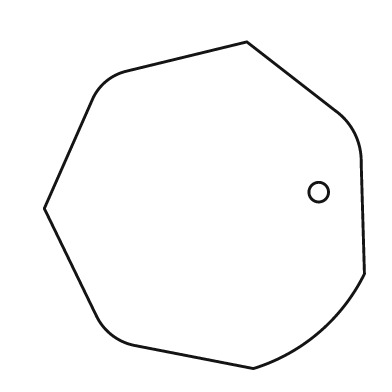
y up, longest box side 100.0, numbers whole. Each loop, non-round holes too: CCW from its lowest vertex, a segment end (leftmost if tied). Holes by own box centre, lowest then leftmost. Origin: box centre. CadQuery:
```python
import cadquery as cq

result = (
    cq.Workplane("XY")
    .moveTo(15.0, -50.0)
    .threePointArc((35.0, -39.0), (49.0, -21.0))
    .lineTo(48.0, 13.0)
    .threePointArc((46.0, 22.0), (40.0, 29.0))
    .lineTo(13.0, 50.0)
    .lineTo(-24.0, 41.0)
    .threePointArc((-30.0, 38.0), (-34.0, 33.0))
    .lineTo(-49.0, -1.0)
    .lineTo(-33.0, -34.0)
    .threePointArc((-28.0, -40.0), (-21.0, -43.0))
    .close()
    .moveTo(35.0, 4.0)
    .circle(3.0)
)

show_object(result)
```